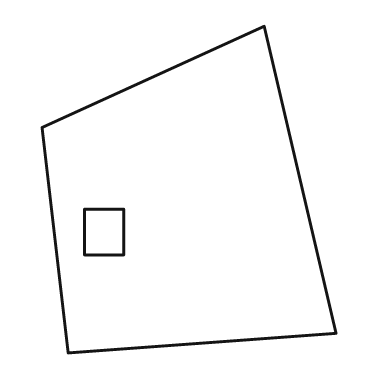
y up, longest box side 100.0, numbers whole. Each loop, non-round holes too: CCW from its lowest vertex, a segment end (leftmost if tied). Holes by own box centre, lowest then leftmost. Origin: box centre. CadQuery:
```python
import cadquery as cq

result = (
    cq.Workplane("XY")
    .moveTo(-37.0, -50.0)
    .lineTo(45.0, -44.0)
    .lineTo(23.0, 50.0)
    .lineTo(-45.0, 19.0)
    .close()
    .moveTo(-32.0, -20.0)
    .lineTo(-20.0, -20.0)
    .lineTo(-20.0, -6.0)
    .lineTo(-32.0, -6.0)
    .close()
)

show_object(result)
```